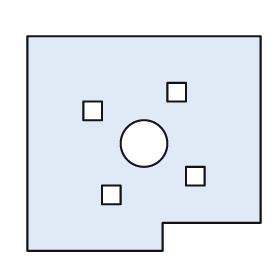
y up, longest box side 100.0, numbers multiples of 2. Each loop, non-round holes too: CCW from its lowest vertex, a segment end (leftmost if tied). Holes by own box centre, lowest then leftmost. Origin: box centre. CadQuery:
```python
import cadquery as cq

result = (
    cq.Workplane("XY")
    .moveTo(-50.0, -46.0)
    .lineTo(8.0, -46.0)
    .lineTo(8.0, -34.0)
    .lineTo(50.0, -34.0)
    .lineTo(50.0, 46.0)
    .lineTo(-50.0, 46.0)
    .close()
    .moveTo(-18.0, -26.0)
    .lineTo(-10.0, -26.0)
    .lineTo(-10.0, -18.0)
    .lineTo(-18.0, -18.0)
    .close()
    .moveTo(18.0, -18.0)
    .lineTo(26.0, -18.0)
    .lineTo(26.0, -10.0)
    .lineTo(18.0, -10.0)
    .close()
    .moveTo(0.0, 0.0)
    .circle(10.0)
    .moveTo(-26.0, 10.0)
    .lineTo(-18.0, 10.0)
    .lineTo(-18.0, 18.0)
    .lineTo(-26.0, 18.0)
    .close()
    .moveTo(10.0, 18.0)
    .lineTo(18.0, 18.0)
    .lineTo(18.0, 26.0)
    .lineTo(10.0, 26.0)
    .close()
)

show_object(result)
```